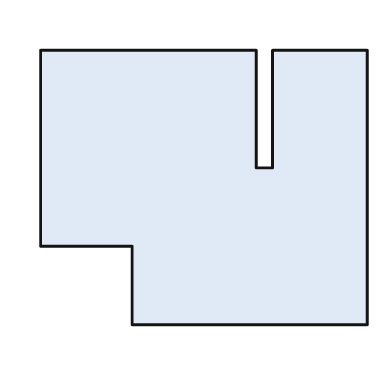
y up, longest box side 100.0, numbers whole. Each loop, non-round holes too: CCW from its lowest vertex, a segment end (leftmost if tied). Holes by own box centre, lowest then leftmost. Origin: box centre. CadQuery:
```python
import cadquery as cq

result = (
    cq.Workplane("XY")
    .moveTo(-22.0, -42.0)
    .lineTo(50.0, -42.0)
    .lineTo(50.0, 42.0)
    .lineTo(21.0, 42.0)
    .lineTo(21.0, 6.0)
    .lineTo(16.0, 6.0)
    .lineTo(16.0, 42.0)
    .lineTo(-50.0, 42.0)
    .lineTo(-50.0, -18.0)
    .lineTo(-22.0, -18.0)
    .close()
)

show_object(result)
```